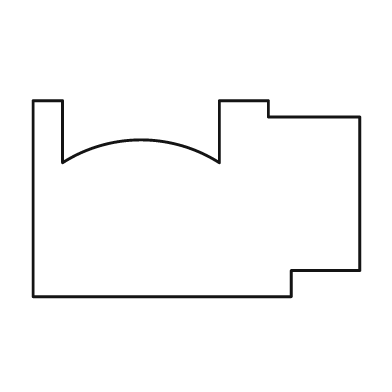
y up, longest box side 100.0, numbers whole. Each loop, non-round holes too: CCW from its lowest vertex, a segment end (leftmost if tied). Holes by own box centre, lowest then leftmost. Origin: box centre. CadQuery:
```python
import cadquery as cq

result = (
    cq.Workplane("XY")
    .moveTo(-50.0, -30.0)
    .lineTo(29.0, -30.0)
    .lineTo(29.0, -22.0)
    .lineTo(50.0, -22.0)
    .lineTo(50.0, 25.0)
    .lineTo(22.0, 25.0)
    .lineTo(22.0, 30.0)
    .lineTo(7.0, 30.0)
    .lineTo(7.0, 11.0)
    .threePointArc((-17.0, 18.0), (-41.0, 11.0))
    .lineTo(-41.0, 30.0)
    .lineTo(-50.0, 30.0)
    .close()
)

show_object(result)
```